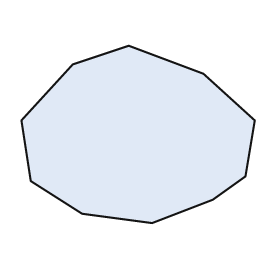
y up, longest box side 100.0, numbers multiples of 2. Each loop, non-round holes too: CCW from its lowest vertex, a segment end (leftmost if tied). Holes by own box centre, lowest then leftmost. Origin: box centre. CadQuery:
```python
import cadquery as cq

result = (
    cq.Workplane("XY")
    .moveTo(6.0, -38.0)
    .lineTo(32.0, -28.0)
    .lineTo(46.0, -18.0)
    .lineTo(50.0, 6.0)
    .lineTo(28.0, 26.0)
    .lineTo(-4.0, 38.0)
    .lineTo(-28.0, 30.0)
    .lineTo(-50.0, 6.0)
    .lineTo(-46.0, -20.0)
    .lineTo(-24.0, -34.0)
    .close()
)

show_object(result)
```